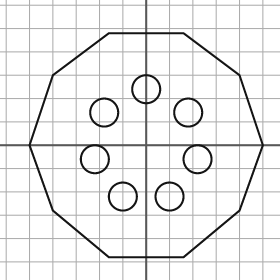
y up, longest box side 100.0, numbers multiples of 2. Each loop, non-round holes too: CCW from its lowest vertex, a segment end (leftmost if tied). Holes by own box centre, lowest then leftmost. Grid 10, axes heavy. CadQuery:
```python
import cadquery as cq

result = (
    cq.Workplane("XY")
    .moveTo(-16.0, -48.0)
    .lineTo(16.0, -48.0)
    .lineTo(40.0, -28.0)
    .lineTo(50.0, 0.0)
    .lineTo(40.0, 30.0)
    .lineTo(16.0, 48.0)
    .lineTo(-16.0, 48.0)
    .lineTo(-40.0, 30.0)
    .lineTo(-50.0, 0.0)
    .lineTo(-40.0, -28.0)
    .close()
    .moveTo(-10.0, -22.0)
    .circle(6.0)
    .moveTo(10.0, -22.0)
    .circle(6.0)
    .moveTo(-22.0, -6.0)
    .circle(6.0)
    .moveTo(22.0, -6.0)
    .circle(6.0)
    .moveTo(-18.0, 14.0)
    .circle(6.0)
    .moveTo(18.0, 14.0)
    .circle(6.0)
    .moveTo(0.0, 24.0)
    .circle(6.0)
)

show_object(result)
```